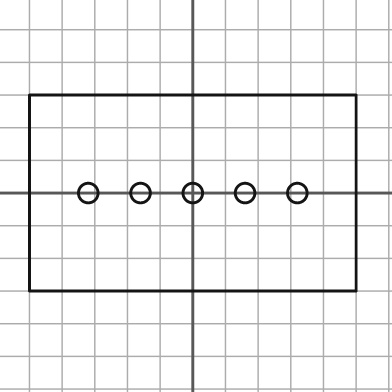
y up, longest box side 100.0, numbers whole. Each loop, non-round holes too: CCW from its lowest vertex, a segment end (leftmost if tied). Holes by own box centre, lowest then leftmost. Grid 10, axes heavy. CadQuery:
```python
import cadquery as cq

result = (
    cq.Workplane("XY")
    .moveTo(-50.0, -30.0)
    .lineTo(50.0, -30.0)
    .lineTo(50.0, 30.0)
    .lineTo(-50.0, 30.0)
    .close()
    .moveTo(-32.0, 0.0)
    .circle(3.0)
    .moveTo(-16.0, 0.0)
    .circle(3.0)
    .moveTo(0.0, 0.0)
    .circle(3.0)
    .moveTo(16.0, 0.0)
    .circle(3.0)
    .moveTo(32.0, 0.0)
    .circle(3.0)
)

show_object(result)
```